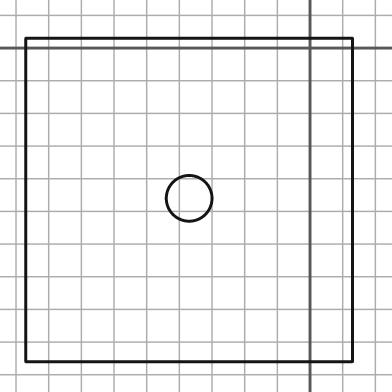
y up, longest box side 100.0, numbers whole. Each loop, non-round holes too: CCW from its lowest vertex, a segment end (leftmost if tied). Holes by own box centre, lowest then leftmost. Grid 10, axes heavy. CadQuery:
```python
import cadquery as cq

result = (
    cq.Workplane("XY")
    .moveTo(-87.0, -96.0)
    .lineTo(13.0, -96.0)
    .lineTo(13.0, 3.0)
    .lineTo(-87.0, 3.0)
    .close()
    .moveTo(-37.0, -46.0)
    .circle(7.0)
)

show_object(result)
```